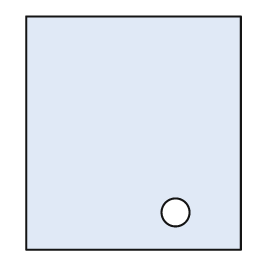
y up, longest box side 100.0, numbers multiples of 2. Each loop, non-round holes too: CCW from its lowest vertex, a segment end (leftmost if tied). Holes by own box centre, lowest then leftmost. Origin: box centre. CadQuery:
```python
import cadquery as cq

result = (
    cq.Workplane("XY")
    .moveTo(-46.0, -50.0)
    .lineTo(46.0, -50.0)
    .lineTo(46.0, 50.0)
    .lineTo(-46.0, 50.0)
    .close()
    .moveTo(18.0, -34.0)
    .circle(6.0)
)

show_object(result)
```